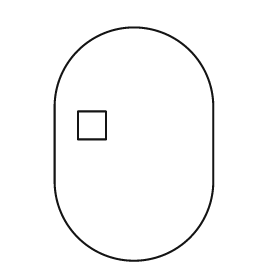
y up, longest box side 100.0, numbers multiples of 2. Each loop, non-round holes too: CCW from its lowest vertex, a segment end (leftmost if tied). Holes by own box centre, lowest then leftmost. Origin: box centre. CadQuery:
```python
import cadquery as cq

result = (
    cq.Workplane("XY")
    .moveTo(-34.0, -16.0)
    .threePointArc((0.0, -50.0), (34.0, -16.0))
    .lineTo(34.0, 16.0)
    .threePointArc((0.0, 50.0), (-34.0, 16.0))
    .close()
    .moveTo(-24.0, 2.0)
    .lineTo(-12.0, 2.0)
    .lineTo(-12.0, 14.0)
    .lineTo(-24.0, 14.0)
    .close()
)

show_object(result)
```